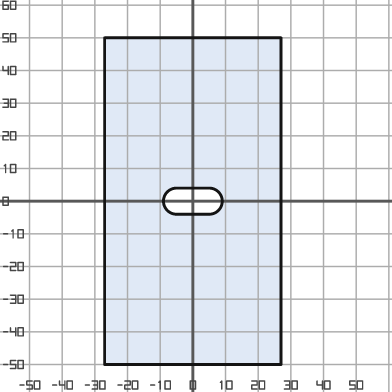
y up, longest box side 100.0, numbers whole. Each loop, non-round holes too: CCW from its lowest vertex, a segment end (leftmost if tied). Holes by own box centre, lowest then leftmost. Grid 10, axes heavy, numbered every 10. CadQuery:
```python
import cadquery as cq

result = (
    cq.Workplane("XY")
    .moveTo(-27.0, -50.0)
    .lineTo(27.0, -50.0)
    .lineTo(27.0, 50.0)
    .lineTo(-27.0, 50.0)
    .close()
    .moveTo(-5.0, -4.0)
    .lineTo(5.0, -4.0)
    .threePointArc((9.0, 0.0), (5.0, 4.0))
    .lineTo(-5.0, 4.0)
    .threePointArc((-9.0, 0.0), (-5.0, -4.0))
    .close()
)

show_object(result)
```